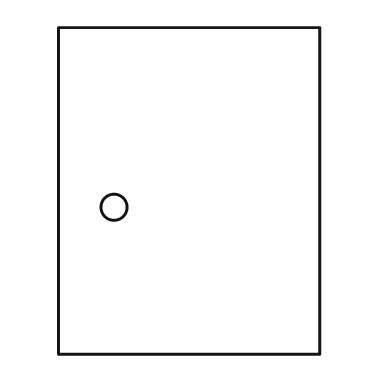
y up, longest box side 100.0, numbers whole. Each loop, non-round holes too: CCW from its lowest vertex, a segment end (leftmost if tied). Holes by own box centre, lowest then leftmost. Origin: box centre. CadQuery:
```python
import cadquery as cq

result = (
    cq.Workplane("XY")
    .moveTo(-40.0, -50.0)
    .lineTo(40.0, -50.0)
    .lineTo(40.0, 50.0)
    .lineTo(-40.0, 50.0)
    .close()
    .moveTo(-23.0, -5.0)
    .circle(4.0)
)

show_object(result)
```